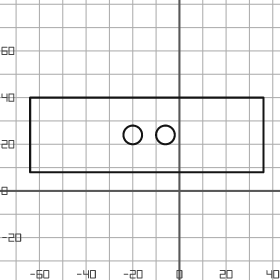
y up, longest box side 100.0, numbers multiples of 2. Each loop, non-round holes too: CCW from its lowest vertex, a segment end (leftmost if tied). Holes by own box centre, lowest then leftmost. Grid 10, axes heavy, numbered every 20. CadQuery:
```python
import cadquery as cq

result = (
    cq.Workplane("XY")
    .moveTo(-64.0, 8.0)
    .lineTo(36.0, 8.0)
    .lineTo(36.0, 40.0)
    .lineTo(-64.0, 40.0)
    .close()
    .moveTo(-20.0, 24.0)
    .circle(4.0)
    .moveTo(-6.0, 24.0)
    .circle(4.0)
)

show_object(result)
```